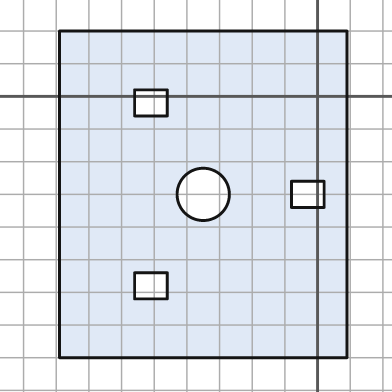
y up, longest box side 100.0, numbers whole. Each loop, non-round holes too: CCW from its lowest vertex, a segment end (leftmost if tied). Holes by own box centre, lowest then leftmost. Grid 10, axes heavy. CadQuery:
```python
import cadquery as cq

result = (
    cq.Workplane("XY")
    .moveTo(-79.0, -80.0)
    .lineTo(9.0, -80.0)
    .lineTo(9.0, 20.0)
    .lineTo(-79.0, 20.0)
    .close()
    .moveTo(-56.0, -62.0)
    .lineTo(-46.0, -62.0)
    .lineTo(-46.0, -54.0)
    .lineTo(-56.0, -54.0)
    .close()
    .moveTo(-35.0, -30.0)
    .circle(8.0)
    .moveTo(-8.0, -34.0)
    .lineTo(2.0, -34.0)
    .lineTo(2.0, -26.0)
    .lineTo(-8.0, -26.0)
    .close()
    .moveTo(-56.0, -6.0)
    .lineTo(-46.0, -6.0)
    .lineTo(-46.0, 2.0)
    .lineTo(-56.0, 2.0)
    .close()
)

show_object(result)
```